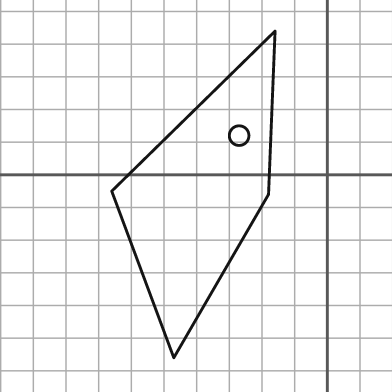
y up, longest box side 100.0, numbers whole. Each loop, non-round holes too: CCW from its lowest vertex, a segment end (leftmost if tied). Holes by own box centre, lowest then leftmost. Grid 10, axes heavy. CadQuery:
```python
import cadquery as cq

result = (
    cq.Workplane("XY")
    .moveTo(-47.0, -56.0)
    .lineTo(-18.0, -6.0)
    .lineTo(-16.0, 44.0)
    .lineTo(-66.0, -5.0)
    .close()
    .moveTo(-27.0, 12.0)
    .circle(3.0)
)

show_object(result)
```